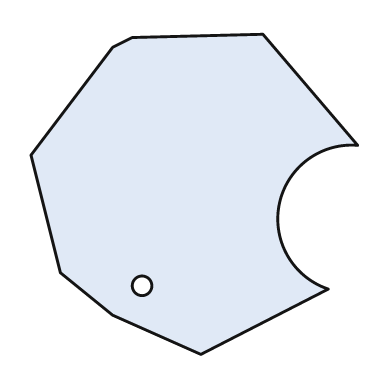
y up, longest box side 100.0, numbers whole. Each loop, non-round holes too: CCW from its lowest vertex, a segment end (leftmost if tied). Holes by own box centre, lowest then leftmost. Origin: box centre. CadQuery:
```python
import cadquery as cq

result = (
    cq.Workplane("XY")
    .moveTo(2.0, -49.0)
    .lineTo(41.0, -29.0)
    .threePointArc((26.0, -3.0), (50.0, 15.0))
    .lineTo(21.0, 49.0)
    .lineTo(-19.0, 48.0)
    .lineTo(-25.0, 45.0)
    .lineTo(-50.0, 12.0)
    .lineTo(-41.0, -24.0)
    .lineTo(-25.0, -37.0)
    .close()
    .moveTo(-16.0, -28.0)
    .circle(3.0)
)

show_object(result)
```